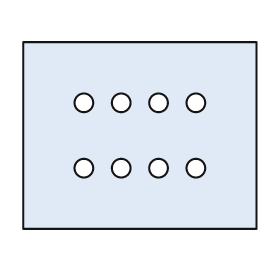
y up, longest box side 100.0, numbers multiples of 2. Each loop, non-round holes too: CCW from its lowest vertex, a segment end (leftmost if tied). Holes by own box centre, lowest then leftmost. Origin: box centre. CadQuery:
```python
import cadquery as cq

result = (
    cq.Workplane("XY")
    .moveTo(-50.0, -40.0)
    .lineTo(50.0, -40.0)
    .lineTo(50.0, 40.0)
    .lineTo(-50.0, 40.0)
    .close()
    .moveTo(-24.0, -14.0)
    .circle(4.0)
    .moveTo(-8.0, -14.0)
    .circle(4.0)
    .moveTo(8.0, -14.0)
    .circle(4.0)
    .moveTo(24.0, -14.0)
    .circle(4.0)
    .moveTo(-24.0, 14.0)
    .circle(4.0)
    .moveTo(-8.0, 14.0)
    .circle(4.0)
    .moveTo(8.0, 14.0)
    .circle(4.0)
    .moveTo(24.0, 14.0)
    .circle(4.0)
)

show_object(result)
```